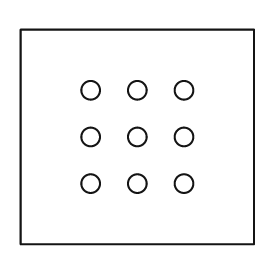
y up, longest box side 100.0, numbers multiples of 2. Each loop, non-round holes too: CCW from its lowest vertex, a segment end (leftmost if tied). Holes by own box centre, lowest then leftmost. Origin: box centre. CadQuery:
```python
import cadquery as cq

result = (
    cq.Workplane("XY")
    .moveTo(-50.0, -46.0)
    .lineTo(50.0, -46.0)
    .lineTo(50.0, 46.0)
    .lineTo(-50.0, 46.0)
    .close()
    .moveTo(-20.0, -20.0)
    .circle(4.0)
    .moveTo(0.0, -20.0)
    .circle(4.0)
    .moveTo(20.0, -20.0)
    .circle(4.0)
    .moveTo(-20.0, 0.0)
    .circle(4.0)
    .moveTo(0.0, 0.0)
    .circle(4.0)
    .moveTo(20.0, 0.0)
    .circle(4.0)
    .moveTo(-20.0, 20.0)
    .circle(4.0)
    .moveTo(0.0, 20.0)
    .circle(4.0)
    .moveTo(20.0, 20.0)
    .circle(4.0)
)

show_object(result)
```